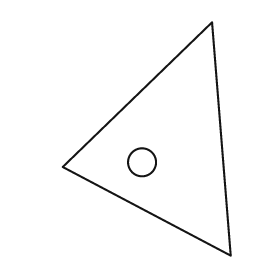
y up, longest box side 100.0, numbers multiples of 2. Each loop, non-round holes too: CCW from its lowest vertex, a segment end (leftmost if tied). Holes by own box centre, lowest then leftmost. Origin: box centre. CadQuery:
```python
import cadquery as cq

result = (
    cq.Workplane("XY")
    .moveTo(36.0, -50.0)
    .lineTo(28.0, 50.0)
    .lineTo(-36.0, -12.0)
    .close()
    .moveTo(-2.0, -10.0)
    .circle(6.0)
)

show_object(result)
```